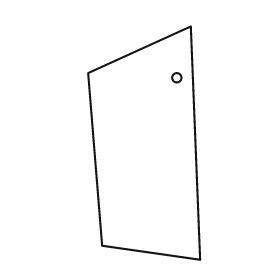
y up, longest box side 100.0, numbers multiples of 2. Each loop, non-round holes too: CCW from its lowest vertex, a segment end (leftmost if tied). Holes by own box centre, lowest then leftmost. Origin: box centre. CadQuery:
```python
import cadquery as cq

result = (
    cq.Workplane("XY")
    .moveTo(24.0, -50.0)
    .lineTo(20.0, 50.0)
    .lineTo(-24.0, 30.0)
    .lineTo(-18.0, -44.0)
    .close()
    .moveTo(14.0, 28.0)
    .circle(2.0)
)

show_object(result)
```